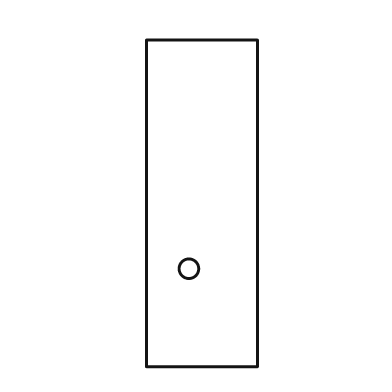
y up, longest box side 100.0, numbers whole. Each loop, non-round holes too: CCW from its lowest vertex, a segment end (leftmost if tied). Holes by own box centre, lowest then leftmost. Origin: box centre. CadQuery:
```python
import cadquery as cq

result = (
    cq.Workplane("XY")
    .moveTo(-17.0, -50.0)
    .lineTo(17.0, -50.0)
    .lineTo(17.0, 50.0)
    .lineTo(-17.0, 50.0)
    .close()
    .moveTo(-4.0, -20.0)
    .circle(3.0)
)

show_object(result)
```